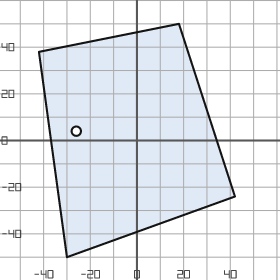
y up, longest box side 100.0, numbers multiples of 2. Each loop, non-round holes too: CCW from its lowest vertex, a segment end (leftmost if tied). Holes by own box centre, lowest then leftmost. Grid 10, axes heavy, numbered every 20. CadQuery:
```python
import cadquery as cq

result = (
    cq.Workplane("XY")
    .moveTo(-30.0, -50.0)
    .lineTo(42.0, -24.0)
    .lineTo(18.0, 50.0)
    .lineTo(-42.0, 38.0)
    .close()
    .moveTo(-26.0, 4.0)
    .circle(2.0)
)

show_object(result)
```